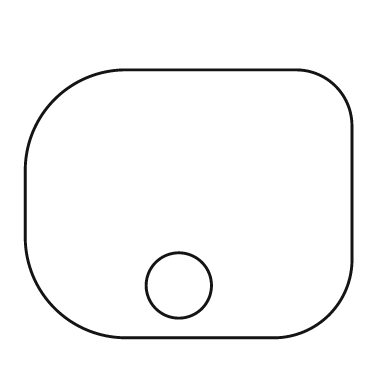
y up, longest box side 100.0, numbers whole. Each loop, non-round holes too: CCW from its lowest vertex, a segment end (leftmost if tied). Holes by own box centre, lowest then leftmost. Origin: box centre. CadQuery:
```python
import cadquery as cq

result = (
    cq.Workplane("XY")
    .moveTo(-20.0, -41.0)
    .lineTo(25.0, -41.0)
    .threePointArc((43.0, -34.0), (50.0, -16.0))
    .lineTo(50.0, 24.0)
    .threePointArc((45.0, 36.0), (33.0, 41.0))
    .lineTo(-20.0, 41.0)
    .threePointArc((-41.0, 32.0), (-50.0, 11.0))
    .lineTo(-50.0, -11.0)
    .threePointArc((-41.0, -32.0), (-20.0, -41.0))
    .close()
    .moveTo(-3.0, -25.0)
    .circle(10.0)
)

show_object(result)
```